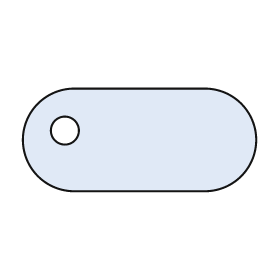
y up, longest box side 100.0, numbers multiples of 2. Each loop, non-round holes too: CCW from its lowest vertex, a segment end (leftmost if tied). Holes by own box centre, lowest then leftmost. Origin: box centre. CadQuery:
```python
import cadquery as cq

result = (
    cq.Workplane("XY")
    .moveTo(-28.0, -22.0)
    .lineTo(28.0, -22.0)
    .threePointArc((50.0, 0.0), (28.0, 22.0))
    .lineTo(-28.0, 22.0)
    .threePointArc((-50.0, 0.0), (-28.0, -22.0))
    .close()
    .moveTo(-32.0, 4.0)
    .circle(6.0)
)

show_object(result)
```